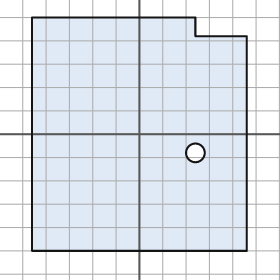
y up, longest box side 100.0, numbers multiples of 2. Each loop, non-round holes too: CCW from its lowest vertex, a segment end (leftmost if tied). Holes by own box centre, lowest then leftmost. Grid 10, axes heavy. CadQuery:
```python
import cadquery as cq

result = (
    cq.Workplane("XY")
    .moveTo(-46.0, -50.0)
    .lineTo(46.0, -50.0)
    .lineTo(46.0, 42.0)
    .lineTo(24.0, 42.0)
    .lineTo(24.0, 50.0)
    .lineTo(-46.0, 50.0)
    .close()
    .moveTo(24.0, -8.0)
    .circle(4.0)
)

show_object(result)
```